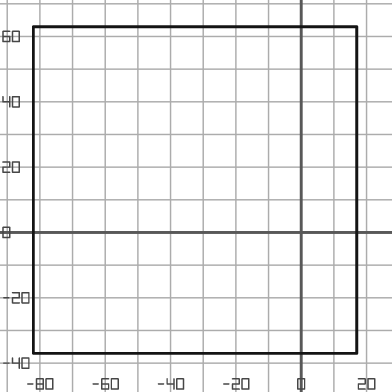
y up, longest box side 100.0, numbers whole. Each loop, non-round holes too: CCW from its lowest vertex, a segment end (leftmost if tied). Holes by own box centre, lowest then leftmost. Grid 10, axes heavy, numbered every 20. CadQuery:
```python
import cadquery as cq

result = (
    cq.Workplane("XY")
    .moveTo(-82.0, -37.0)
    .lineTo(17.0, -37.0)
    .lineTo(17.0, 63.0)
    .lineTo(-82.0, 63.0)
    .close()
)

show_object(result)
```